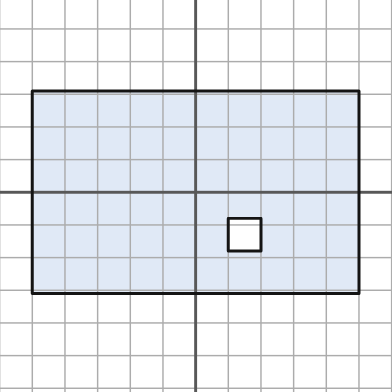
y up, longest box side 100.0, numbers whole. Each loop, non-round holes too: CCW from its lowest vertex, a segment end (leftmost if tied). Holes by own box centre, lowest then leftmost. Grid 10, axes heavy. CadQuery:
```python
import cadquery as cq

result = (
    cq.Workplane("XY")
    .moveTo(-50.0, -31.0)
    .lineTo(50.0, -31.0)
    .lineTo(50.0, 31.0)
    .lineTo(-50.0, 31.0)
    .close()
    .moveTo(10.0, -18.0)
    .lineTo(20.0, -18.0)
    .lineTo(20.0, -8.0)
    .lineTo(10.0, -8.0)
    .close()
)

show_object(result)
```